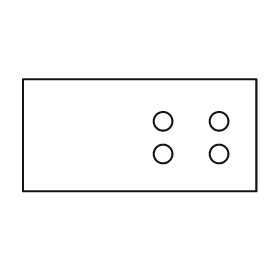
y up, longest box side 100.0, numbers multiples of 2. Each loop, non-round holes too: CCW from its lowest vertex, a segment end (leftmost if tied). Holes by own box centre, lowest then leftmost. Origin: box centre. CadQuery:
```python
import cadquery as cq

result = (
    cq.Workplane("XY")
    .moveTo(-50.0, -24.0)
    .lineTo(50.0, -24.0)
    .lineTo(50.0, 24.0)
    .lineTo(-50.0, 24.0)
    .close()
    .moveTo(10.0, -8.0)
    .circle(4.0)
    .moveTo(34.0, -8.0)
    .circle(4.0)
    .moveTo(10.0, 6.0)
    .circle(4.0)
    .moveTo(34.0, 6.0)
    .circle(4.0)
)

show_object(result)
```